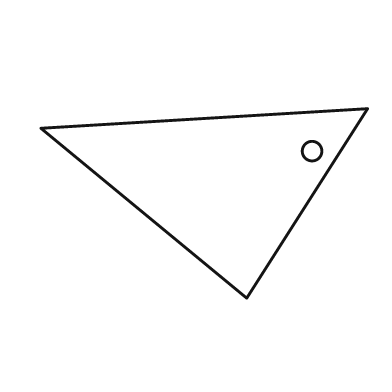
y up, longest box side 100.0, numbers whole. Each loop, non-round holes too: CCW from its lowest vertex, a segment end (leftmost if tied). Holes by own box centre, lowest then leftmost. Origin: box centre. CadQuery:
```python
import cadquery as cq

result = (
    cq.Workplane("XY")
    .moveTo(13.0, -29.0)
    .lineTo(50.0, 29.0)
    .lineTo(-50.0, 23.0)
    .close()
    .moveTo(33.0, 16.0)
    .circle(3.0)
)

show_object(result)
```